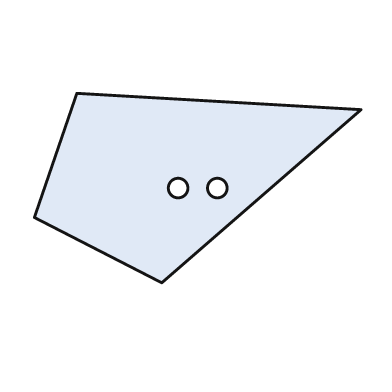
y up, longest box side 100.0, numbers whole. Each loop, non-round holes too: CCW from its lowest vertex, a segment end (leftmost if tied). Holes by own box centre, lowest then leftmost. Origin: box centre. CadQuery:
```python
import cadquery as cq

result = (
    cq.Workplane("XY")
    .moveTo(-11.0, -29.0)
    .lineTo(50.0, 24.0)
    .lineTo(-37.0, 29.0)
    .lineTo(-50.0, -9.0)
    .close()
    .moveTo(-6.0, 0.0)
    .circle(3.0)
    .moveTo(6.0, 0.0)
    .circle(3.0)
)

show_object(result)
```